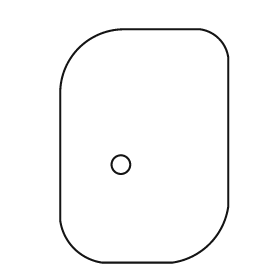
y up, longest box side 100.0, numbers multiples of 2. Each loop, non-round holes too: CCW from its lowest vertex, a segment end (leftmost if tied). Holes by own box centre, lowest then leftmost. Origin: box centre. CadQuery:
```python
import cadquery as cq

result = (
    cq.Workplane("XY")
    .moveTo(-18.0, -50.0)
    .lineTo(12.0, -50.0)
    .threePointArc((28.0, -42.0), (36.0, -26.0))
    .lineTo(36.0, 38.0)
    .threePointArc((32.0, 46.0), (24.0, 50.0))
    .lineTo(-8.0, 50.0)
    .threePointArc((-28.0, 42.0), (-36.0, 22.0))
    .lineTo(-36.0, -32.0)
    .threePointArc((-30.0, -44.0), (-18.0, -50.0))
    .close()
    .moveTo(-10.0, -8.0)
    .circle(4.0)
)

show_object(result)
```